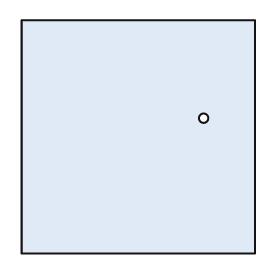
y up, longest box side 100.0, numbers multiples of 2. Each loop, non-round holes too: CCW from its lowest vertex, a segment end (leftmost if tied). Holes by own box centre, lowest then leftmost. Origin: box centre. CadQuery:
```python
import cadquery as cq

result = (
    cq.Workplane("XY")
    .moveTo(-50.0, -50.0)
    .lineTo(50.0, -50.0)
    .lineTo(50.0, 50.0)
    .lineTo(-50.0, 50.0)
    .close()
    .moveTo(28.0, 8.0)
    .circle(2.0)
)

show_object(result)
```